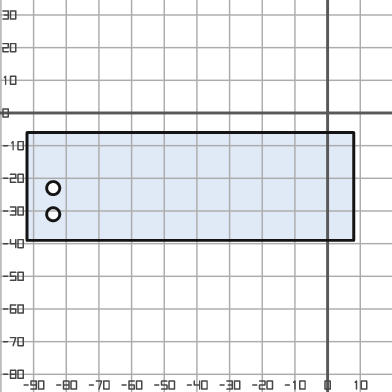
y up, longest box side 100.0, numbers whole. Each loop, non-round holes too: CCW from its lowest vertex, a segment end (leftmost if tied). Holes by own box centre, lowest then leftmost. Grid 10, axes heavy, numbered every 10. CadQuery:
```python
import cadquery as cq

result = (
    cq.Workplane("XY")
    .moveTo(-92.0, -39.0)
    .lineTo(8.0, -39.0)
    .lineTo(8.0, -6.0)
    .lineTo(-92.0, -6.0)
    .close()
    .moveTo(-84.0, -31.0)
    .circle(2.0)
    .moveTo(-84.0, -23.0)
    .circle(2.0)
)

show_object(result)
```